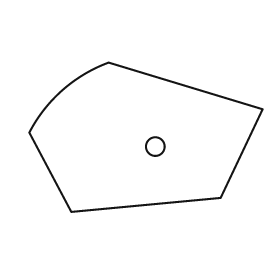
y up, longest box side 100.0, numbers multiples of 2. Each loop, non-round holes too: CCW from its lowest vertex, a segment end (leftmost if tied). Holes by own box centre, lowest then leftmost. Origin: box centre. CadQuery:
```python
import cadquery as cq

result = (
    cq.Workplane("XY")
    .moveTo(-32.0, -32.0)
    .lineTo(32.0, -26.0)
    .lineTo(50.0, 12.0)
    .lineTo(-16.0, 32.0)
    .threePointArc((-36.0, 20.0), (-50.0, 2.0))
    .close()
    .moveTo(4.0, -4.0)
    .circle(4.0)
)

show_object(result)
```